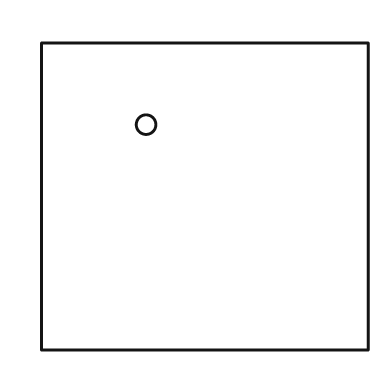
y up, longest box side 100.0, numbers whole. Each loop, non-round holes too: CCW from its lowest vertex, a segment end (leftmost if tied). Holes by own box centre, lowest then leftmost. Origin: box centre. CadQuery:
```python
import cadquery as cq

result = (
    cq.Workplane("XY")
    .moveTo(-50.0, -47.0)
    .lineTo(50.0, -47.0)
    .lineTo(50.0, 47.0)
    .lineTo(-50.0, 47.0)
    .close()
    .moveTo(-18.0, 22.0)
    .circle(3.0)
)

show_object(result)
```